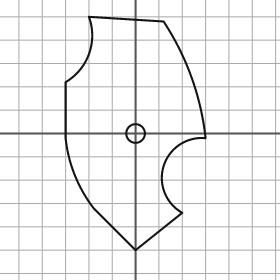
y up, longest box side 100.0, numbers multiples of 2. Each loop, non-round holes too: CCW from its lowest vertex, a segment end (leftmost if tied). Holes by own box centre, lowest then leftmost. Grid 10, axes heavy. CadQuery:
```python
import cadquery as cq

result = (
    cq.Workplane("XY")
    .moveTo(0.0, -50.0)
    .lineTo(20.0, -34.0)
    .threePointArc((12.0, -14.0), (30.0, -2.0))
    .threePointArc((24.0, 24.0), (12.0, 48.0))
    .lineTo(-20.0, 50.0)
    .threePointArc((-20.0, 34.0), (-30.0, 22.0))
    .lineTo(-30.0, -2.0)
    .threePointArc((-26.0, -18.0), (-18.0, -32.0))
    .close()
    .moveTo(0.0, 0.0)
    .circle(4.0)
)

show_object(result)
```